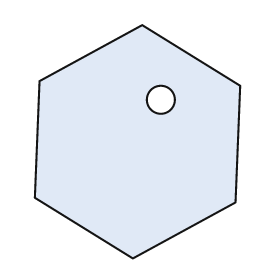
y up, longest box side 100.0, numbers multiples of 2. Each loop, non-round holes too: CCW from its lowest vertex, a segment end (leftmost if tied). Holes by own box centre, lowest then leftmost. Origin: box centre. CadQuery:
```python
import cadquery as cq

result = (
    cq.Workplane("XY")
    .moveTo(-2.0, -50.0)
    .lineTo(42.0, -26.0)
    .lineTo(44.0, 24.0)
    .lineTo(2.0, 50.0)
    .lineTo(-42.0, 26.0)
    .lineTo(-44.0, -24.0)
    .close()
    .moveTo(10.0, 18.0)
    .circle(6.0)
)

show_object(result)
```